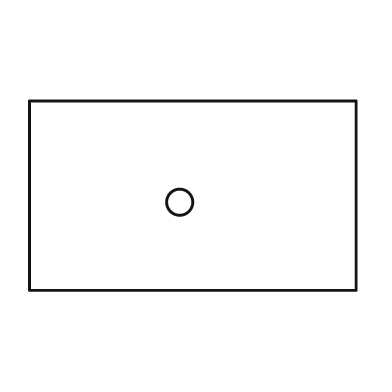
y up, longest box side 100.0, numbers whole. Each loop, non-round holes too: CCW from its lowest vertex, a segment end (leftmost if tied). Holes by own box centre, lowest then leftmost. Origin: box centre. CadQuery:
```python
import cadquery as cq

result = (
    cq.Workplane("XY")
    .moveTo(-50.0, -29.0)
    .lineTo(50.0, -29.0)
    .lineTo(50.0, 29.0)
    .lineTo(-50.0, 29.0)
    .close()
    .moveTo(-4.0, -2.0)
    .circle(4.0)
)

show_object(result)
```